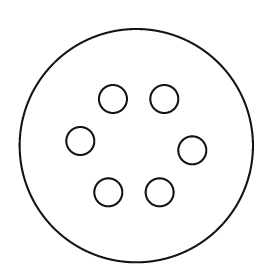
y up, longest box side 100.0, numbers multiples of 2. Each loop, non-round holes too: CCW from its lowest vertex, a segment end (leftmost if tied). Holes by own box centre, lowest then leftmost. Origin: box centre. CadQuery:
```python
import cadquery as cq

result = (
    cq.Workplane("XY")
    .moveTo(0.0, 0.0)
    .circle(50.0)
    .moveTo(-12.0, -20.0)
    .circle(6.0)
    .moveTo(10.0, -20.0)
    .circle(6.0)
    .moveTo(24.0, -2.0)
    .circle(6.0)
    .moveTo(-24.0, 2.0)
    .circle(6.0)
    .moveTo(-10.0, 20.0)
    .circle(6.0)
    .moveTo(12.0, 20.0)
    .circle(6.0)
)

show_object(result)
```